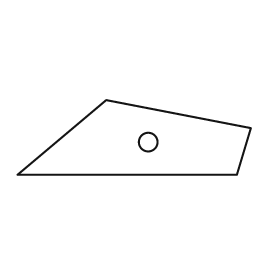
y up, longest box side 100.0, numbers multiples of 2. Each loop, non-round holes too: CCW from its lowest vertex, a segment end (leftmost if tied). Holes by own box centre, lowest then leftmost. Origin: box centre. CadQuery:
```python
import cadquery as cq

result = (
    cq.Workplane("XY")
    .moveTo(-50.0, -16.0)
    .lineTo(44.0, -16.0)
    .lineTo(50.0, 4.0)
    .lineTo(-12.0, 16.0)
    .close()
    .moveTo(6.0, -2.0)
    .circle(4.0)
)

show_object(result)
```